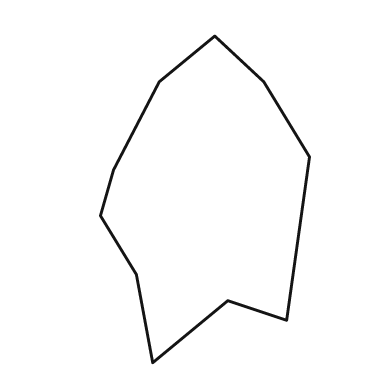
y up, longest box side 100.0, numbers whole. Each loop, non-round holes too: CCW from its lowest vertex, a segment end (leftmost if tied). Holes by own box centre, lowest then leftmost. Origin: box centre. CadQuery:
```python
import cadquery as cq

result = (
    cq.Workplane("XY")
    .moveTo(-16.0, -50.0)
    .lineTo(7.0, -31.0)
    .lineTo(25.0, -37.0)
    .lineTo(32.0, 13.0)
    .lineTo(18.0, 36.0)
    .lineTo(3.0, 50.0)
    .lineTo(-14.0, 36.0)
    .lineTo(-28.0, 9.0)
    .lineTo(-32.0, -5.0)
    .lineTo(-21.0, -23.0)
    .close()
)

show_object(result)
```